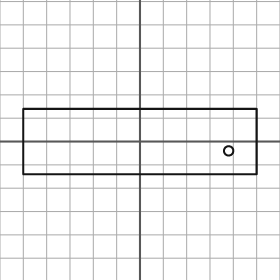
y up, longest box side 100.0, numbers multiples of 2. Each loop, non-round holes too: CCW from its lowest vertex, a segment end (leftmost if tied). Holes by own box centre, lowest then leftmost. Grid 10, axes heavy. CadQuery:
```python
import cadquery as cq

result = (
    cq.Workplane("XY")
    .moveTo(-50.0, -14.0)
    .lineTo(50.0, -14.0)
    .lineTo(50.0, 14.0)
    .lineTo(-50.0, 14.0)
    .close()
    .moveTo(38.0, -4.0)
    .circle(2.0)
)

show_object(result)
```